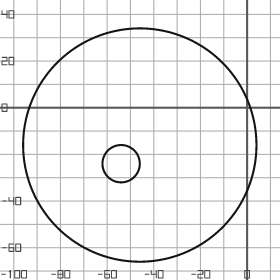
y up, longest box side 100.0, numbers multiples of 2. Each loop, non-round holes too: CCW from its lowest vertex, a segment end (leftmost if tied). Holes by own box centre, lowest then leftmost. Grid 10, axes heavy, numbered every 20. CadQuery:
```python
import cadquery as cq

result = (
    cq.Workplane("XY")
    .moveTo(-46.0, -16.0)
    .circle(50.0)
    .moveTo(-54.0, -24.0)
    .circle(8.0)
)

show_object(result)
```